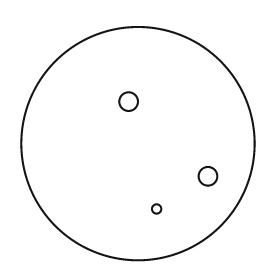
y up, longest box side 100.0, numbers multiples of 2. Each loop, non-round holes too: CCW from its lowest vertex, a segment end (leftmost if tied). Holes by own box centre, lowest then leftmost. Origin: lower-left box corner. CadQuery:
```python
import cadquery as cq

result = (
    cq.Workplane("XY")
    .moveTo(50.0, 50.0)
    .circle(50.0)
    .moveTo(58.0, 22.0)
    .circle(2.0)
    .moveTo(80.0, 36.0)
    .circle(4.0)
    .moveTo(46.0, 68.0)
    .circle(4.0)
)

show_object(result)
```